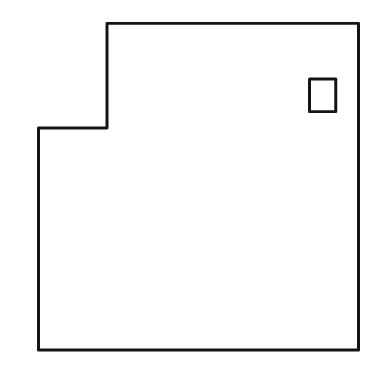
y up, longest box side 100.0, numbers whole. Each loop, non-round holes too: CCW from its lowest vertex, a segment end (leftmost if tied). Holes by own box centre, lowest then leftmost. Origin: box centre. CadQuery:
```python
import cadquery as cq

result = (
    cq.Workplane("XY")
    .moveTo(-49.0, -50.0)
    .lineTo(49.0, -50.0)
    .lineTo(49.0, 50.0)
    .lineTo(-28.0, 50.0)
    .lineTo(-28.0, 18.0)
    .lineTo(-49.0, 18.0)
    .close()
    .moveTo(34.0, 23.0)
    .lineTo(42.0, 23.0)
    .lineTo(42.0, 33.0)
    .lineTo(34.0, 33.0)
    .close()
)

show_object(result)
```